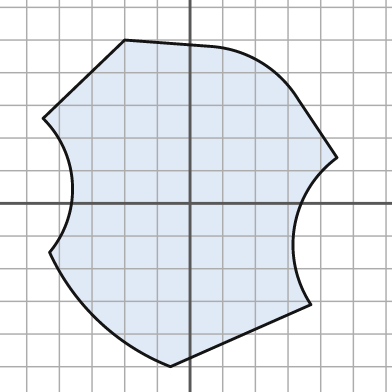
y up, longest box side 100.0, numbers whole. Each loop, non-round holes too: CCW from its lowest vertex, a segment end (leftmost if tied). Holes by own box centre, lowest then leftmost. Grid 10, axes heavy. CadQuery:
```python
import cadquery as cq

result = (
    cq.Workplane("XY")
    .moveTo(-6.0, -50.0)
    .lineTo(37.0, -31.0)
    .threePointArc((32.0, -7.0), (45.0, 14.0))
    .lineTo(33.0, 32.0)
    .threePointArc((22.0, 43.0), (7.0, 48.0))
    .lineTo(-20.0, 50.0)
    .lineTo(-45.0, 26.0)
    .threePointArc((-36.0, 6.0), (-43.0, -15.0))
    .threePointArc((-28.0, -36.0), (-6.0, -50.0))
    .close()
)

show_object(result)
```